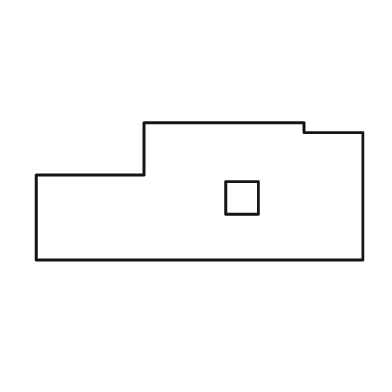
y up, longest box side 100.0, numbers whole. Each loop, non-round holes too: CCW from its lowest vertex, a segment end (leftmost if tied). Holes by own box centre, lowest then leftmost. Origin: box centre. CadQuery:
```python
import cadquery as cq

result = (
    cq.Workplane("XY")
    .moveTo(-50.0, -21.0)
    .lineTo(50.0, -21.0)
    .lineTo(50.0, 18.0)
    .lineTo(32.0, 18.0)
    .lineTo(32.0, 21.0)
    .lineTo(-17.0, 21.0)
    .lineTo(-17.0, 5.0)
    .lineTo(-50.0, 5.0)
    .close()
    .moveTo(8.0, -7.0)
    .lineTo(18.0, -7.0)
    .lineTo(18.0, 3.0)
    .lineTo(8.0, 3.0)
    .close()
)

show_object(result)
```